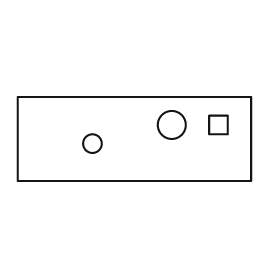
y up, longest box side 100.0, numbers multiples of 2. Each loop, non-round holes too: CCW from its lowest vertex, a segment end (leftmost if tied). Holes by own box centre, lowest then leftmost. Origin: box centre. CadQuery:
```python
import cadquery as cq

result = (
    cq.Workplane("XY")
    .moveTo(-50.0, -18.0)
    .lineTo(50.0, -18.0)
    .lineTo(50.0, 18.0)
    .lineTo(-50.0, 18.0)
    .close()
    .moveTo(-18.0, -2.0)
    .circle(4.0)
    .moveTo(16.0, 6.0)
    .circle(6.0)
    .moveTo(32.0, 2.0)
    .lineTo(40.0, 2.0)
    .lineTo(40.0, 10.0)
    .lineTo(32.0, 10.0)
    .close()
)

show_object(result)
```